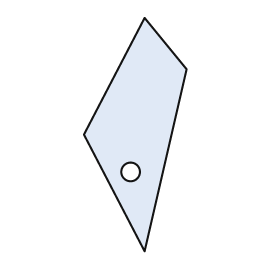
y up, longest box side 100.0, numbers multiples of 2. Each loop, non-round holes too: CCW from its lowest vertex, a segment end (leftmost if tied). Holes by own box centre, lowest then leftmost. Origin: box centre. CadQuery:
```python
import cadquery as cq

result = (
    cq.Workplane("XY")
    .moveTo(4.0, -50.0)
    .lineTo(22.0, 28.0)
    .lineTo(4.0, 50.0)
    .lineTo(-22.0, 0.0)
    .close()
    .moveTo(-2.0, -16.0)
    .circle(4.0)
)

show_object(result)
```